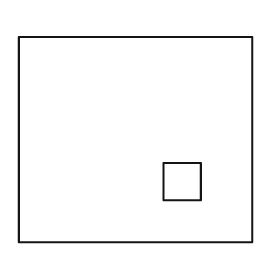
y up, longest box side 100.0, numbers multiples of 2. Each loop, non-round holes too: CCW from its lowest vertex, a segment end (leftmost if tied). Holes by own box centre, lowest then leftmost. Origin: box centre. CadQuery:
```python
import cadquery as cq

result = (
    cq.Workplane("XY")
    .moveTo(-50.0, -44.0)
    .lineTo(50.0, -44.0)
    .lineTo(50.0, 44.0)
    .lineTo(-50.0, 44.0)
    .close()
    .moveTo(12.0, -26.0)
    .lineTo(28.0, -26.0)
    .lineTo(28.0, -10.0)
    .lineTo(12.0, -10.0)
    .close()
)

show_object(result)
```